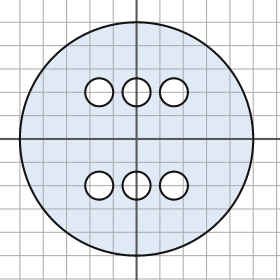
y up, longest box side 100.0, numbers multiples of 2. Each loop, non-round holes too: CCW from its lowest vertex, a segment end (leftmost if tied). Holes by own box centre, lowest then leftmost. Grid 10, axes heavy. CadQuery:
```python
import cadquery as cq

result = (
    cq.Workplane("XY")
    .moveTo(0.0, 0.0)
    .circle(50.0)
    .moveTo(-16.0, -20.0)
    .circle(6.0)
    .moveTo(0.0, -20.0)
    .circle(6.0)
    .moveTo(16.0, -20.0)
    .circle(6.0)
    .moveTo(-16.0, 20.0)
    .circle(6.0)
    .moveTo(0.0, 20.0)
    .circle(6.0)
    .moveTo(16.0, 20.0)
    .circle(6.0)
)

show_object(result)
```